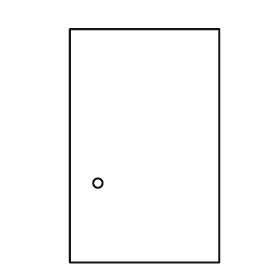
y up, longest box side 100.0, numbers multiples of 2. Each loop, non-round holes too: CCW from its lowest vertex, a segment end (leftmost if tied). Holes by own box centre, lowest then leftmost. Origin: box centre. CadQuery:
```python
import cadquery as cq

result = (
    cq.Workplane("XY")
    .moveTo(-32.0, -50.0)
    .lineTo(32.0, -50.0)
    .lineTo(32.0, 50.0)
    .lineTo(-32.0, 50.0)
    .close()
    .moveTo(-20.0, -16.0)
    .circle(2.0)
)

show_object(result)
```